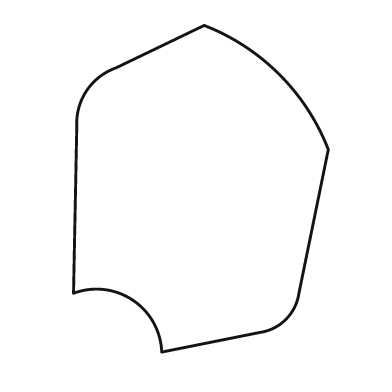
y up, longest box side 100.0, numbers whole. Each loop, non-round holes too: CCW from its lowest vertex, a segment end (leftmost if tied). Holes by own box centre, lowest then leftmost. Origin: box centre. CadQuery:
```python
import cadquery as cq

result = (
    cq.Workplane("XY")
    .moveTo(-12.0, -50.0)
    .lineTo(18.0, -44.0)
    .threePointArc((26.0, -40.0), (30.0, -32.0))
    .lineTo(39.0, 12.0)
    .threePointArc((24.0, 35.0), (1.0, 50.0))
    .lineTo(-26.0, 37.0)
    .threePointArc((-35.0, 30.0), (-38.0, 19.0))
    .lineTo(-39.0, -32.0)
    .threePointArc((-21.0, -34.0), (-12.0, -50.0))
    .close()
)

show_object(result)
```